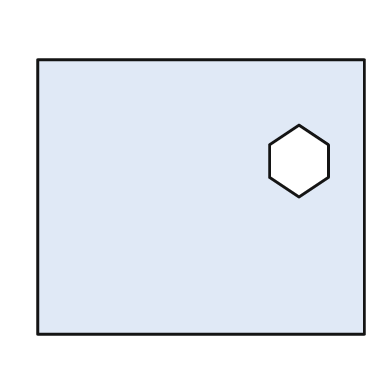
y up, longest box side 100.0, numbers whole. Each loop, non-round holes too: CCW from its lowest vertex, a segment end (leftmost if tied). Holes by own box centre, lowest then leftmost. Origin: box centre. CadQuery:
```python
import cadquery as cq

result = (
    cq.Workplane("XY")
    .moveTo(-50.0, -42.0)
    .lineTo(50.0, -42.0)
    .lineTo(50.0, 42.0)
    .lineTo(-50.0, 42.0)
    .close()
    .moveTo(30.0, 0.0)
    .lineTo(39.0, 6.0)
    .lineTo(39.0, 16.0)
    .lineTo(30.0, 22.0)
    .lineTo(21.0, 16.0)
    .lineTo(21.0, 6.0)
    .close()
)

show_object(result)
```